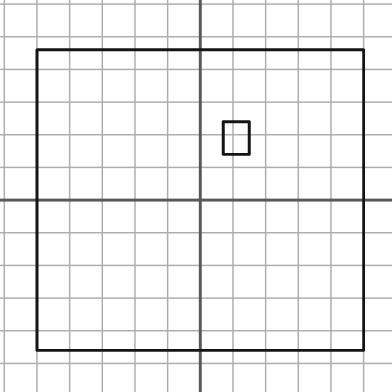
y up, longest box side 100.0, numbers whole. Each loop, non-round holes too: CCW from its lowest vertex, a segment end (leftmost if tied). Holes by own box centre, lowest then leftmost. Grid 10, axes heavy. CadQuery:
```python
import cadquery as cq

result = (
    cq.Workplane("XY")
    .moveTo(-50.0, -46.0)
    .lineTo(50.0, -46.0)
    .lineTo(50.0, 46.0)
    .lineTo(-50.0, 46.0)
    .close()
    .moveTo(7.0, 14.0)
    .lineTo(15.0, 14.0)
    .lineTo(15.0, 24.0)
    .lineTo(7.0, 24.0)
    .close()
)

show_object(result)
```